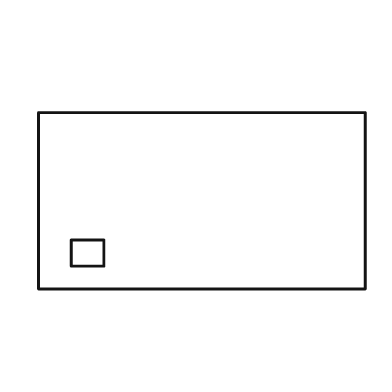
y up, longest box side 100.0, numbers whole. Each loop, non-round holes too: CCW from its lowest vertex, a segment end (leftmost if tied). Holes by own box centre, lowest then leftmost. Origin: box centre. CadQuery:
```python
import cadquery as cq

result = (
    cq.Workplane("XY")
    .moveTo(-50.0, -27.0)
    .lineTo(50.0, -27.0)
    .lineTo(50.0, 27.0)
    .lineTo(-50.0, 27.0)
    .close()
    .moveTo(-40.0, -20.0)
    .lineTo(-30.0, -20.0)
    .lineTo(-30.0, -12.0)
    .lineTo(-40.0, -12.0)
    .close()
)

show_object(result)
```